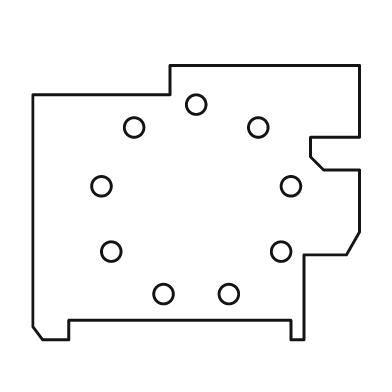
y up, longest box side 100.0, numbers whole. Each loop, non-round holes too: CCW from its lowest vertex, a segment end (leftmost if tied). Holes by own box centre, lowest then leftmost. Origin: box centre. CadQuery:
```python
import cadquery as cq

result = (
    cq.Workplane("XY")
    .moveTo(-47.0, -42.0)
    .lineTo(-39.0, -42.0)
    .lineTo(-39.0, -36.0)
    .lineTo(29.0, -36.0)
    .lineTo(29.0, -42.0)
    .lineTo(33.0, -42.0)
    .lineTo(33.0, -16.0)
    .lineTo(46.0, -16.0)
    .lineTo(50.0, -9.0)
    .lineTo(50.0, 10.0)
    .lineTo(39.0, 10.0)
    .lineTo(35.0, 14.0)
    .lineTo(35.0, 20.0)
    .lineTo(50.0, 20.0)
    .lineTo(50.0, 42.0)
    .lineTo(-8.0, 42.0)
    .lineTo(-8.0, 33.0)
    .lineTo(-50.0, 33.0)
    .lineTo(-50.0, -38.0)
    .close()
    .moveTo(-10.0, -28.0)
    .circle(3.0)
    .moveTo(10.0, -28.0)
    .circle(3.0)
    .moveTo(-26.0, -15.0)
    .circle(3.0)
    .moveTo(26.0, -15.0)
    .circle(3.0)
    .moveTo(-29.0, 5.0)
    .circle(3.0)
    .moveTo(29.0, 5.0)
    .circle(3.0)
    .moveTo(-19.0, 23.0)
    .circle(3.0)
    .moveTo(19.0, 23.0)
    .circle(3.0)
    .moveTo(0.0, 30.0)
    .circle(3.0)
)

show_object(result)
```